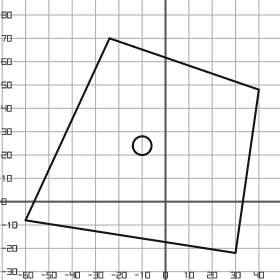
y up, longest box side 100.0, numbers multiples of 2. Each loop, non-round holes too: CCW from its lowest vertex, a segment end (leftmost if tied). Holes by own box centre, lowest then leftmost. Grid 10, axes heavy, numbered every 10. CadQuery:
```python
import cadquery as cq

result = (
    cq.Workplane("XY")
    .moveTo(30.0, -22.0)
    .lineTo(40.0, 48.0)
    .lineTo(-24.0, 70.0)
    .lineTo(-60.0, -8.0)
    .close()
    .moveTo(-10.0, 24.0)
    .circle(4.0)
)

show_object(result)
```